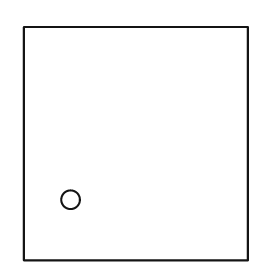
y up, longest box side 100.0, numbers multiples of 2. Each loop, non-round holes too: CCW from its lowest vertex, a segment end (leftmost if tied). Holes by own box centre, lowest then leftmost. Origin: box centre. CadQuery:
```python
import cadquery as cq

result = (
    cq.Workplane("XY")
    .moveTo(-48.0, -50.0)
    .lineTo(48.0, -50.0)
    .lineTo(48.0, 50.0)
    .lineTo(-48.0, 50.0)
    .close()
    .moveTo(-28.0, -24.0)
    .circle(4.0)
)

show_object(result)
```